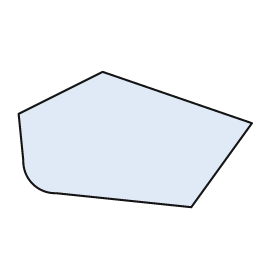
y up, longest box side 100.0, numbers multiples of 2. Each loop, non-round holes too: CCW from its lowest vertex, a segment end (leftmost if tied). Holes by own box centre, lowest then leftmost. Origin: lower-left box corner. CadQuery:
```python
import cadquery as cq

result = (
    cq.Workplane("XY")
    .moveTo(74.0, 0.0)
    .lineTo(100.0, 36.0)
    .lineTo(36.0, 58.0)
    .lineTo(0.0, 40.0)
    .lineTo(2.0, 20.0)
    .threePointArc((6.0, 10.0), (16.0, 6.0))
    .close()
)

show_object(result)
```